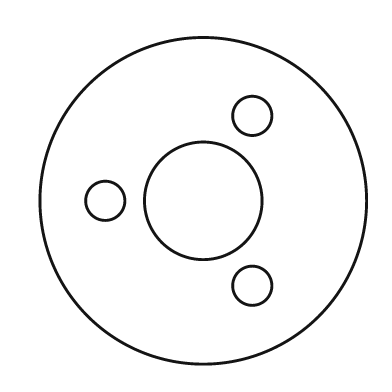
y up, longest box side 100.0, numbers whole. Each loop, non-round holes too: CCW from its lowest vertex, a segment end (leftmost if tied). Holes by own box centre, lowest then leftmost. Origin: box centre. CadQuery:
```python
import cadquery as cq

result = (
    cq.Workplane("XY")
    .moveTo(0.0, 0.0)
    .circle(50.0)
    .moveTo(15.0, -26.0)
    .circle(6.0)
    .moveTo(-30.0, 0.0)
    .circle(6.0)
    .moveTo(0.0, 0.0)
    .circle(18.0)
    .moveTo(15.0, 26.0)
    .circle(6.0)
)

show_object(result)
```